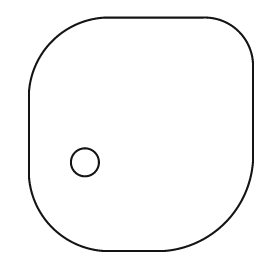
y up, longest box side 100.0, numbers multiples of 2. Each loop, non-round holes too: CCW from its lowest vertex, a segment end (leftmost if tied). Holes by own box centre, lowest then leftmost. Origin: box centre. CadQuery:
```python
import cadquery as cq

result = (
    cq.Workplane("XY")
    .moveTo(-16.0, -50.0)
    .lineTo(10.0, -50.0)
    .threePointArc((36.0, -38.0), (48.0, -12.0))
    .lineTo(48.0, 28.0)
    .threePointArc((42.0, 44.0), (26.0, 50.0))
    .lineTo(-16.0, 50.0)
    .threePointArc((-38.0, 40.0), (-48.0, 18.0))
    .lineTo(-48.0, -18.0)
    .threePointArc((-38.0, -40.0), (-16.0, -50.0))
    .close()
    .moveTo(-24.0, -12.0)
    .circle(6.0)
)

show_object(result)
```